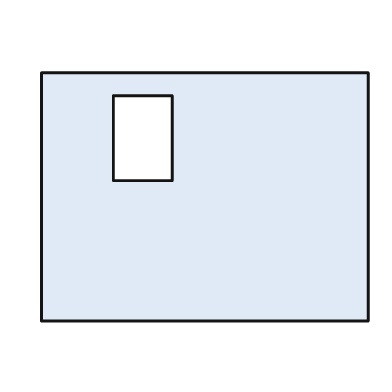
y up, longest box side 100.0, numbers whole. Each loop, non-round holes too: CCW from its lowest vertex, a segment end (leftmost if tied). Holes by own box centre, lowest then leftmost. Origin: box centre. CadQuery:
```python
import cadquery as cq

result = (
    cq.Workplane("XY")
    .moveTo(-50.0, -38.0)
    .lineTo(50.0, -38.0)
    .lineTo(50.0, 38.0)
    .lineTo(-50.0, 38.0)
    .close()
    .moveTo(-28.0, 5.0)
    .lineTo(-10.0, 5.0)
    .lineTo(-10.0, 31.0)
    .lineTo(-28.0, 31.0)
    .close()
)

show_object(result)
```